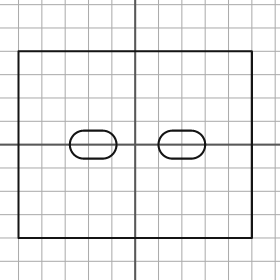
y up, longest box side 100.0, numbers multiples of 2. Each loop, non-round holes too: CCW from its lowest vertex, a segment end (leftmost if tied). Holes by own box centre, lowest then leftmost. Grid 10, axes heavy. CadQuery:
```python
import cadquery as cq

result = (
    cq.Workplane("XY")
    .moveTo(-50.0, -40.0)
    .lineTo(50.0, -40.0)
    .lineTo(50.0, 40.0)
    .lineTo(-50.0, 40.0)
    .close()
    .moveTo(-22.0, -6.0)
    .lineTo(-14.0, -6.0)
    .threePointArc((-8.0, 0.0), (-14.0, 6.0))
    .lineTo(-22.0, 6.0)
    .threePointArc((-28.0, 0.0), (-22.0, -6.0))
    .close()
    .moveTo(16.0, -6.0)
    .lineTo(24.0, -6.0)
    .threePointArc((30.0, 0.0), (24.0, 6.0))
    .lineTo(16.0, 6.0)
    .threePointArc((10.0, 0.0), (16.0, -6.0))
    .close()
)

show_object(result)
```